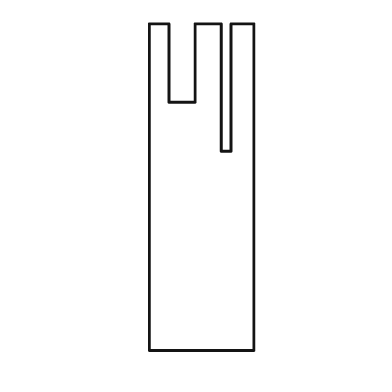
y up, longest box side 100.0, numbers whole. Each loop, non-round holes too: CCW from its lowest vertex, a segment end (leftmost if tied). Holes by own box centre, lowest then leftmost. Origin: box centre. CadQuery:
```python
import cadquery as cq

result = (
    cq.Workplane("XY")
    .moveTo(-16.0, -50.0)
    .lineTo(16.0, -50.0)
    .lineTo(16.0, 50.0)
    .lineTo(9.0, 50.0)
    .lineTo(9.0, 11.0)
    .lineTo(6.0, 11.0)
    .lineTo(6.0, 50.0)
    .lineTo(-2.0, 50.0)
    .lineTo(-2.0, 26.0)
    .lineTo(-10.0, 26.0)
    .lineTo(-10.0, 50.0)
    .lineTo(-16.0, 50.0)
    .close()
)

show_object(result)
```